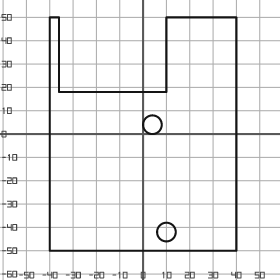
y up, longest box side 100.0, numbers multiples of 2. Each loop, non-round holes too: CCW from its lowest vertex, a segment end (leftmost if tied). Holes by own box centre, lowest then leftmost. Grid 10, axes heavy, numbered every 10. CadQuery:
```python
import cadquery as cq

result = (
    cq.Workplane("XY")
    .moveTo(-40.0, -50.0)
    .lineTo(40.0, -50.0)
    .lineTo(40.0, 50.0)
    .lineTo(10.0, 50.0)
    .lineTo(10.0, 18.0)
    .lineTo(-36.0, 18.0)
    .lineTo(-36.0, 50.0)
    .lineTo(-40.0, 50.0)
    .close()
    .moveTo(10.0, -42.0)
    .circle(4.0)
    .moveTo(4.0, 4.0)
    .circle(4.0)
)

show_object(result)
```